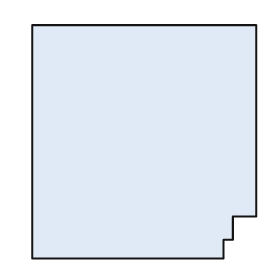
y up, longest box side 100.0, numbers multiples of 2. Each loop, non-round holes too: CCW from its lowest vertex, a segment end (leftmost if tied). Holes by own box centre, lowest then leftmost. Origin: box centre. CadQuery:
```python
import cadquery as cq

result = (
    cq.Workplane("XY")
    .moveTo(-48.0, -50.0)
    .lineTo(34.0, -50.0)
    .lineTo(34.0, -42.0)
    .lineTo(38.0, -42.0)
    .lineTo(38.0, -32.0)
    .lineTo(48.0, -32.0)
    .lineTo(48.0, 50.0)
    .lineTo(-48.0, 50.0)
    .close()
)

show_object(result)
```